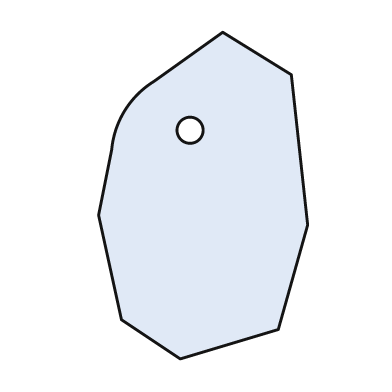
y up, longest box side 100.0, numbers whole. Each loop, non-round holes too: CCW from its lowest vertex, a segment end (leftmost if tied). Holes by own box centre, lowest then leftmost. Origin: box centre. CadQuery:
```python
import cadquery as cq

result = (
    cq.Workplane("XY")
    .moveTo(-7.0, -50.0)
    .lineTo(23.0, -41.0)
    .lineTo(32.0, -9.0)
    .lineTo(27.0, 37.0)
    .lineTo(6.0, 50.0)
    .lineTo(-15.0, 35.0)
    .threePointArc((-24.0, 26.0), (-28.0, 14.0))
    .lineTo(-32.0, -6.0)
    .lineTo(-25.0, -38.0)
    .close()
    .moveTo(-4.0, 20.0)
    .circle(4.0)
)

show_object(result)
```